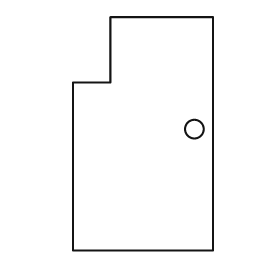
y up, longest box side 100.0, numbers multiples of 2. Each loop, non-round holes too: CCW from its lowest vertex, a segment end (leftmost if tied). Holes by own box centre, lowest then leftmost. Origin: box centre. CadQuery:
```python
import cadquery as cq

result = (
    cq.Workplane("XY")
    .moveTo(-30.0, -50.0)
    .lineTo(30.0, -50.0)
    .lineTo(30.0, 50.0)
    .lineTo(-14.0, 50.0)
    .lineTo(-14.0, 22.0)
    .lineTo(-30.0, 22.0)
    .close()
    .moveTo(22.0, 2.0)
    .circle(4.0)
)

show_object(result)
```